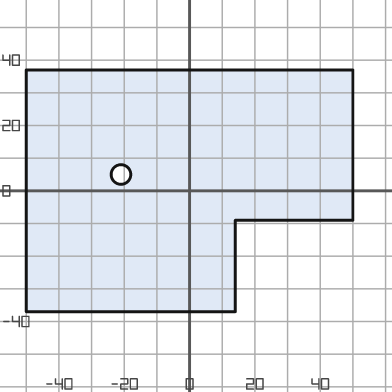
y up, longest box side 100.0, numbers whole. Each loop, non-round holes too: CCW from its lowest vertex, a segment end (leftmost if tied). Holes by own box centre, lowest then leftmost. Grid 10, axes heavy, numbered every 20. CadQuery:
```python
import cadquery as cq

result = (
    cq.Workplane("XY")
    .moveTo(-50.0, -37.0)
    .lineTo(14.0, -37.0)
    .lineTo(14.0, -9.0)
    .lineTo(50.0, -9.0)
    .lineTo(50.0, 37.0)
    .lineTo(-50.0, 37.0)
    .close()
    .moveTo(-21.0, 5.0)
    .circle(3.0)
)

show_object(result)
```